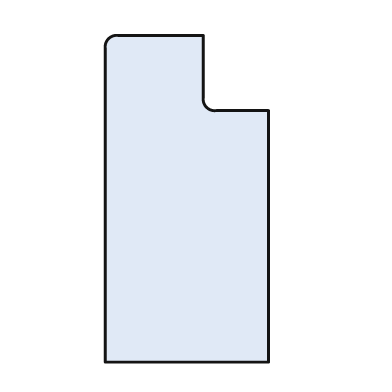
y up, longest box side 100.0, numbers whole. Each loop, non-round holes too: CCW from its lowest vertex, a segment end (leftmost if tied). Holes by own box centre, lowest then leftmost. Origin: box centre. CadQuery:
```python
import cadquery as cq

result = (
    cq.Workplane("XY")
    .moveTo(-25.0, -50.0)
    .lineTo(25.0, -50.0)
    .lineTo(25.0, 27.0)
    .lineTo(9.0, 27.0)
    .threePointArc((6.0, 28.0), (5.0, 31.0))
    .lineTo(5.0, 50.0)
    .lineTo(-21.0, 50.0)
    .threePointArc((-24.0, 49.0), (-25.0, 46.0))
    .close()
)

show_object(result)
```